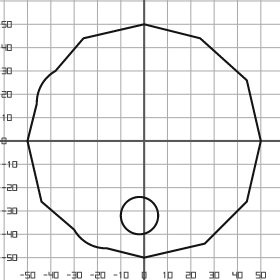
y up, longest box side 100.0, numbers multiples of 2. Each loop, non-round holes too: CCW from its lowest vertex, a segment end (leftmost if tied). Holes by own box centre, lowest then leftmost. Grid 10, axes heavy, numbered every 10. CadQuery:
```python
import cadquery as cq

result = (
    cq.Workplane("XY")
    .moveTo(0.0, -50.0)
    .lineTo(26.0, -44.0)
    .lineTo(44.0, -26.0)
    .lineTo(50.0, 0.0)
    .lineTo(44.0, 26.0)
    .lineTo(24.0, 44.0)
    .lineTo(0.0, 50.0)
    .lineTo(-26.0, 44.0)
    .lineTo(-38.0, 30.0)
    .threePointArc((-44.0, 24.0), (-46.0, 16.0))
    .lineTo(-50.0, 0.0)
    .lineTo(-44.0, -26.0)
    .lineTo(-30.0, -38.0)
    .threePointArc((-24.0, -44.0), (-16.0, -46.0))
    .close()
    .moveTo(-2.0, -32.0)
    .circle(8.0)
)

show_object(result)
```